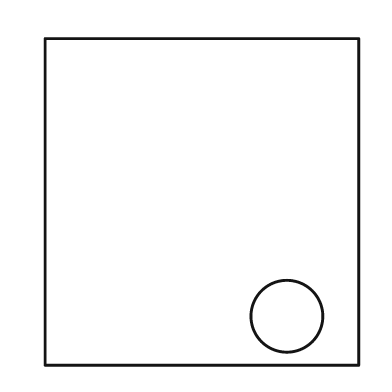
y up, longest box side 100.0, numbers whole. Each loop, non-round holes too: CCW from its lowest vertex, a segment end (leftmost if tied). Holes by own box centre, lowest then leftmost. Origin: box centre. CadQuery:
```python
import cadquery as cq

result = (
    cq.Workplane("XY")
    .moveTo(-48.0, -50.0)
    .lineTo(48.0, -50.0)
    .lineTo(48.0, 50.0)
    .lineTo(-48.0, 50.0)
    .close()
    .moveTo(26.0, -35.0)
    .circle(11.0)
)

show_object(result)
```